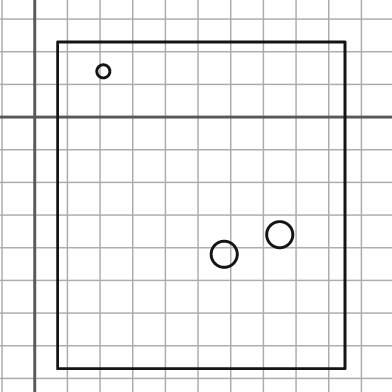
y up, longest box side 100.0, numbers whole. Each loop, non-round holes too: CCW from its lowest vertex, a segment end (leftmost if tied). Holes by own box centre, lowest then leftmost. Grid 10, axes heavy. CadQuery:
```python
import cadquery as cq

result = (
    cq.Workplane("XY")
    .moveTo(7.0, -77.0)
    .lineTo(95.0, -77.0)
    .lineTo(95.0, 23.0)
    .lineTo(7.0, 23.0)
    .close()
    .moveTo(58.0, -42.0)
    .circle(4.0)
    .moveTo(75.0, -36.0)
    .circle(4.0)
    .moveTo(21.0, 14.0)
    .circle(2.0)
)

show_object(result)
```